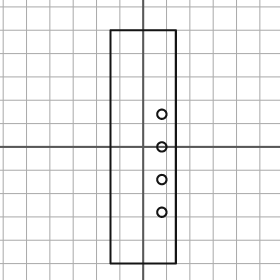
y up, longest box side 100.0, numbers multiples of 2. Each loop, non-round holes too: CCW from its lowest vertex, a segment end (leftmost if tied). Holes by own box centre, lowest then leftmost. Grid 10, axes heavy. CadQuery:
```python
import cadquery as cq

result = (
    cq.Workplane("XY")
    .moveTo(-14.0, -50.0)
    .lineTo(14.0, -50.0)
    .lineTo(14.0, 50.0)
    .lineTo(-14.0, 50.0)
    .close()
    .moveTo(8.0, -28.0)
    .circle(2.0)
    .moveTo(8.0, -14.0)
    .circle(2.0)
    .moveTo(8.0, 0.0)
    .circle(2.0)
    .moveTo(8.0, 14.0)
    .circle(2.0)
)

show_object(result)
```